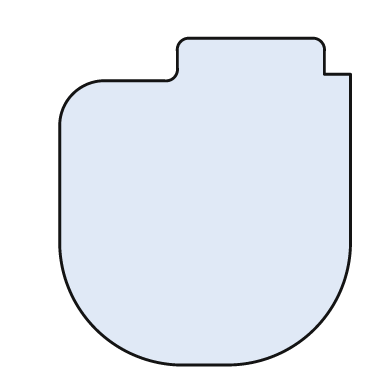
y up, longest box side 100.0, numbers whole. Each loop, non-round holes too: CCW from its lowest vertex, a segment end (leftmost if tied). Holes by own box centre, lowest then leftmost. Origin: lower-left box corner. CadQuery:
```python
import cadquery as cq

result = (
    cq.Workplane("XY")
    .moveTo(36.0, 0.0)
    .lineTo(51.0, 0.0)
    .threePointArc((78.0, 11.0), (89.0, 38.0))
    .lineTo(89.0, 89.0)
    .lineTo(81.0, 89.0)
    .lineTo(81.0, 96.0)
    .threePointArc((80.0, 99.0), (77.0, 100.0))
    .lineTo(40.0, 100.0)
    .threePointArc((37.0, 99.0), (36.0, 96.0))
    .lineTo(36.0, 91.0)
    .threePointArc((35.0, 88.0), (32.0, 87.0))
    .lineTo(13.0, 87.0)
    .threePointArc((4.0, 83.0), (0.0, 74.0))
    .lineTo(0.0, 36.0)
    .threePointArc((11.0, 11.0), (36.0, 0.0))
    .close()
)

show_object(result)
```